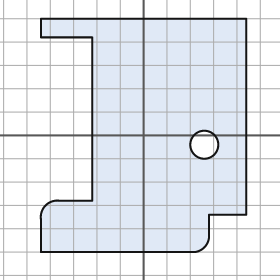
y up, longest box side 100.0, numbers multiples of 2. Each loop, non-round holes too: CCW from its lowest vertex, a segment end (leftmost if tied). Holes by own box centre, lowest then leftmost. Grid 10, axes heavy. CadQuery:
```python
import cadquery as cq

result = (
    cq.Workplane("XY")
    .moveTo(-44.0, -50.0)
    .lineTo(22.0, -50.0)
    .threePointArc((26.0, -48.0), (28.0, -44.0))
    .lineTo(28.0, -34.0)
    .lineTo(44.0, -34.0)
    .lineTo(44.0, 50.0)
    .lineTo(-44.0, 50.0)
    .lineTo(-44.0, 42.0)
    .lineTo(-22.0, 42.0)
    .lineTo(-22.0, -28.0)
    .lineTo(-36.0, -28.0)
    .threePointArc((-42.0, -30.0), (-44.0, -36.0))
    .close()
    .moveTo(26.0, -4.0)
    .circle(6.0)
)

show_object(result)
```